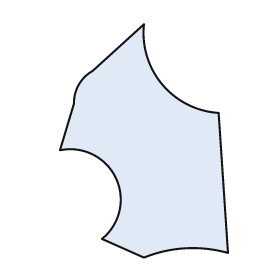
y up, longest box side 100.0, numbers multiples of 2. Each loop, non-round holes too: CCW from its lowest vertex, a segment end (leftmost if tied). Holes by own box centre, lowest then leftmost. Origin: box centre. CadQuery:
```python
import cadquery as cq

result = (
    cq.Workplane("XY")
    .moveTo(0.0, -50.0)
    .threePointArc((18.0, -46.0), (36.0, -48.0))
    .lineTo(32.0, 12.0)
    .threePointArc((8.0, 24.0), (0.0, 50.0))
    .lineTo(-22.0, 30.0)
    .threePointArc((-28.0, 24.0), (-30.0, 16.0))
    .lineTo(-36.0, -4.0)
    .threePointArc((-12.0, -16.0), (-18.0, -42.0))
    .close()
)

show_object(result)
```